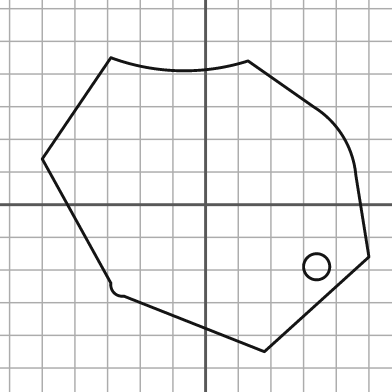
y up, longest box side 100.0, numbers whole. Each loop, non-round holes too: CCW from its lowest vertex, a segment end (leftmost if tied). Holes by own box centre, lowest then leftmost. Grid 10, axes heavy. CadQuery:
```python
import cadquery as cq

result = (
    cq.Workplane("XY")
    .moveTo(18.0, -45.0)
    .lineTo(50.0, -16.0)
    .lineTo(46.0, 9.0)
    .threePointArc((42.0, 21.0), (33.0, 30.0))
    .lineTo(13.0, 44.0)
    .threePointArc((-8.0, 41.0), (-29.0, 45.0))
    .lineTo(-50.0, 14.0)
    .lineTo(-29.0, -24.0)
    .threePointArc((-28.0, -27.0), (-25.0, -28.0))
    .close()
    .moveTo(34.0, -19.0)
    .circle(4.0)
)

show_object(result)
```